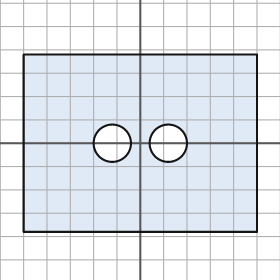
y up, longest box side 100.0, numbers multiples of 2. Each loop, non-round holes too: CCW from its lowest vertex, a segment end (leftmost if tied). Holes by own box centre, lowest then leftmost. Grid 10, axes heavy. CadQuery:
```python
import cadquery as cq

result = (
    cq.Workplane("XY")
    .moveTo(-50.0, -38.0)
    .lineTo(50.0, -38.0)
    .lineTo(50.0, 38.0)
    .lineTo(-50.0, 38.0)
    .close()
    .moveTo(-12.0, 0.0)
    .circle(8.0)
    .moveTo(12.0, 0.0)
    .circle(8.0)
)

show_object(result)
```